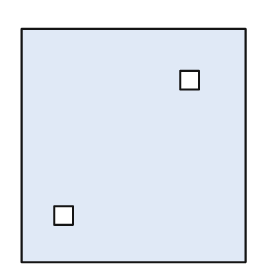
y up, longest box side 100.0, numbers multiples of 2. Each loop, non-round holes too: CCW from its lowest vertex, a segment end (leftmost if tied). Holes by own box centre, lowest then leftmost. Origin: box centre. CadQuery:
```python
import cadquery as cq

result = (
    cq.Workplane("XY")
    .moveTo(-48.0, -50.0)
    .lineTo(48.0, -50.0)
    .lineTo(48.0, 50.0)
    .lineTo(-48.0, 50.0)
    .close()
    .moveTo(-34.0, -34.0)
    .lineTo(-26.0, -34.0)
    .lineTo(-26.0, -26.0)
    .lineTo(-34.0, -26.0)
    .close()
    .moveTo(20.0, 24.0)
    .lineTo(28.0, 24.0)
    .lineTo(28.0, 32.0)
    .lineTo(20.0, 32.0)
    .close()
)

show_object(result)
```